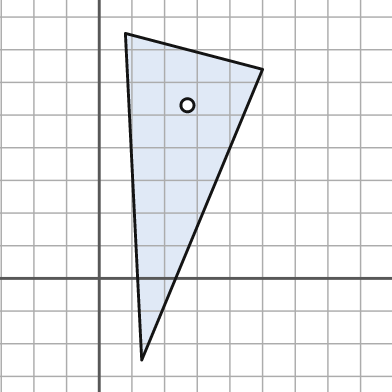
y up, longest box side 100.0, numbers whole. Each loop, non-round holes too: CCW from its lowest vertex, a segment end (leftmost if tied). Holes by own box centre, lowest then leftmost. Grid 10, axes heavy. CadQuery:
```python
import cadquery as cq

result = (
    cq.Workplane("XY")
    .moveTo(13.0, -25.0)
    .lineTo(50.0, 64.0)
    .lineTo(8.0, 75.0)
    .close()
    .moveTo(27.0, 53.0)
    .circle(2.0)
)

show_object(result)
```